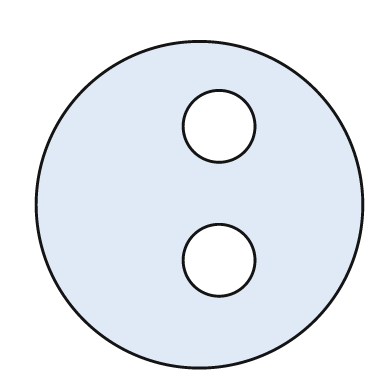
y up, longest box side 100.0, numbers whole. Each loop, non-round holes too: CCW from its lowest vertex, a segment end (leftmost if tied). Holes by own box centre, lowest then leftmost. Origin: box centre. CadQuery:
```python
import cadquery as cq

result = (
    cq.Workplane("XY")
    .moveTo(0.0, 0.0)
    .circle(50.0)
    .moveTo(6.0, -17.0)
    .circle(11.0)
    .moveTo(6.0, 24.0)
    .circle(11.0)
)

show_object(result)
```